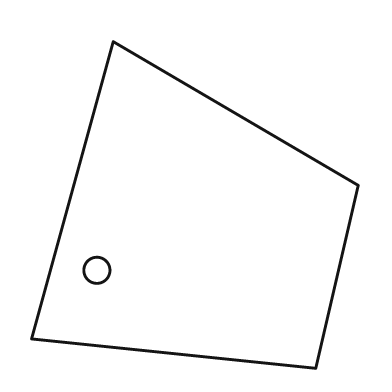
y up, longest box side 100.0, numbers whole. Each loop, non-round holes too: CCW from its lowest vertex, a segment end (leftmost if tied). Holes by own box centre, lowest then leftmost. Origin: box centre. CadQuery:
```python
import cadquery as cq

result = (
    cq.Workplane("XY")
    .moveTo(37.0, -50.0)
    .lineTo(50.0, 6.0)
    .lineTo(-25.0, 50.0)
    .lineTo(-50.0, -41.0)
    .close()
    .moveTo(-30.0, -20.0)
    .circle(4.0)
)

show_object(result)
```